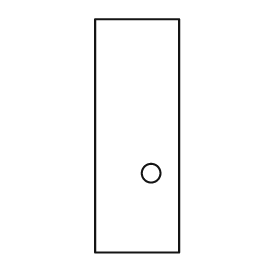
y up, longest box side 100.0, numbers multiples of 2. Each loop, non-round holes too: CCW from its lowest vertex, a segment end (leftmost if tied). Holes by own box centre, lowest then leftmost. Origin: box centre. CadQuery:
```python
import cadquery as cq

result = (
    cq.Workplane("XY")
    .moveTo(-18.0, -50.0)
    .lineTo(18.0, -50.0)
    .lineTo(18.0, 50.0)
    .lineTo(-18.0, 50.0)
    .close()
    .moveTo(6.0, -16.0)
    .circle(4.0)
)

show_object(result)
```